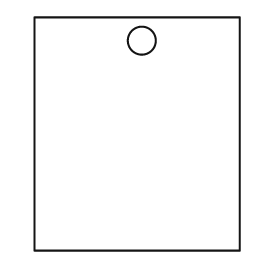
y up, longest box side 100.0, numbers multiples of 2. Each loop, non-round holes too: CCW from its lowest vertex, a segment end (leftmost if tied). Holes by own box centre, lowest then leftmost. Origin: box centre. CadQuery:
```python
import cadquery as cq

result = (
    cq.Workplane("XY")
    .moveTo(-44.0, -50.0)
    .lineTo(44.0, -50.0)
    .lineTo(44.0, 50.0)
    .lineTo(-44.0, 50.0)
    .close()
    .moveTo(2.0, 40.0)
    .circle(6.0)
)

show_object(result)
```